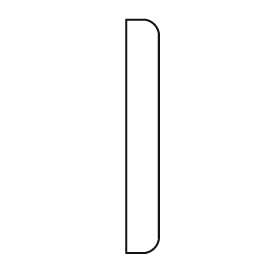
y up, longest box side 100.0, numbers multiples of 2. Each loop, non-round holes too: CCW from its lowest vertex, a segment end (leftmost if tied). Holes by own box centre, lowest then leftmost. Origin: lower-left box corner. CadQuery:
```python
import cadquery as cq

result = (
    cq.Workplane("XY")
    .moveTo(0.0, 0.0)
    .lineTo(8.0, 0.0)
    .threePointArc((12.0, 2.0), (14.0, 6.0))
    .lineTo(14.0, 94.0)
    .threePointArc((12.0, 98.0), (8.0, 100.0))
    .lineTo(0.0, 100.0)
    .close()
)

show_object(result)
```